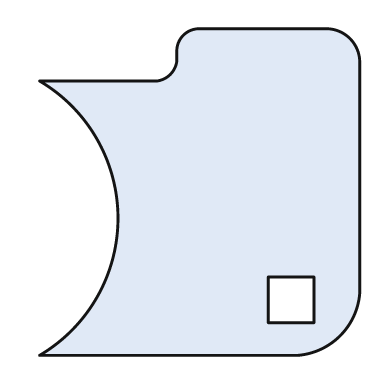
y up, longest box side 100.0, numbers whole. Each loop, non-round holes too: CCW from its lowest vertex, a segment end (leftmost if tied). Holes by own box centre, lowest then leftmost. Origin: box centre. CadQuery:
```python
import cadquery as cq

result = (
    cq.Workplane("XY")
    .moveTo(-49.0, -50.0)
    .lineTo(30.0, -50.0)
    .threePointArc((43.0, -44.0), (49.0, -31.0))
    .lineTo(49.0, 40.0)
    .threePointArc((46.0, 47.0), (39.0, 50.0))
    .lineTo(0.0, 50.0)
    .threePointArc((-5.0, 48.0), (-7.0, 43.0))
    .lineTo(-7.0, 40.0)
    .threePointArc((-9.0, 36.0), (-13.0, 34.0))
    .lineTo(-49.0, 34.0)
    .threePointArc((-25.0, -8.0), (-49.0, -50.0))
    .close()
    .moveTo(21.0, -40.0)
    .lineTo(35.0, -40.0)
    .lineTo(35.0, -26.0)
    .lineTo(21.0, -26.0)
    .close()
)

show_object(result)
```